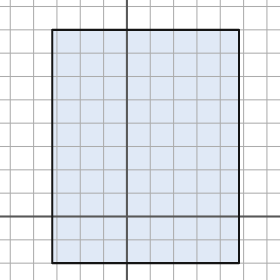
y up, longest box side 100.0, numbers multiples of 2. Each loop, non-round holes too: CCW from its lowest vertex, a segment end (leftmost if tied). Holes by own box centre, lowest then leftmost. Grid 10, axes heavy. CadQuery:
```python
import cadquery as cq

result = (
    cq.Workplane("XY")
    .moveTo(-32.0, -20.0)
    .lineTo(48.0, -20.0)
    .lineTo(48.0, 80.0)
    .lineTo(-32.0, 80.0)
    .close()
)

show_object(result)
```